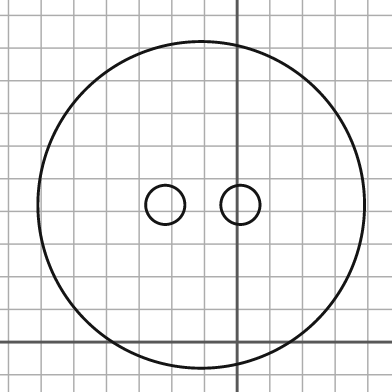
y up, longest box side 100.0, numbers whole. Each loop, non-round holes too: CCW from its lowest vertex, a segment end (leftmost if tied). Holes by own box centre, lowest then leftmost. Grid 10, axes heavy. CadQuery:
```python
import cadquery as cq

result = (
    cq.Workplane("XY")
    .moveTo(-11.0, 42.0)
    .circle(50.0)
    .moveTo(-22.0, 42.0)
    .circle(6.0)
    .moveTo(1.0, 42.0)
    .circle(6.0)
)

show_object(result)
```